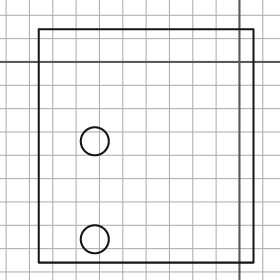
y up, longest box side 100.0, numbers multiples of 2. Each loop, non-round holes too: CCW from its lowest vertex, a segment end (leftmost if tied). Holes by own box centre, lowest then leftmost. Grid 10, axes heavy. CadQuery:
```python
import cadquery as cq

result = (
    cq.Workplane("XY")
    .moveTo(-86.0, -86.0)
    .lineTo(6.0, -86.0)
    .lineTo(6.0, 14.0)
    .lineTo(-86.0, 14.0)
    .close()
    .moveTo(-62.0, -76.0)
    .circle(6.0)
    .moveTo(-62.0, -34.0)
    .circle(6.0)
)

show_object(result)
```